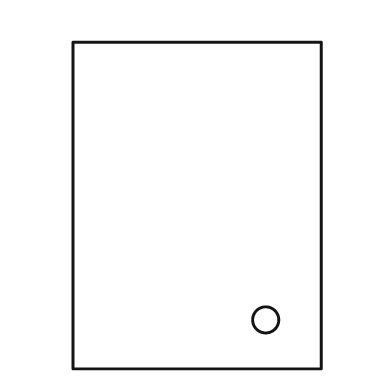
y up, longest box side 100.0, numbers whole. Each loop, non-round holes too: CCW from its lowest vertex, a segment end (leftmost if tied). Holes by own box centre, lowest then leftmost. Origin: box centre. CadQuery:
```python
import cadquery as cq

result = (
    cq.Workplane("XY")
    .moveTo(-38.0, -50.0)
    .lineTo(38.0, -50.0)
    .lineTo(38.0, 50.0)
    .lineTo(-38.0, 50.0)
    .close()
    .moveTo(21.0, -35.0)
    .circle(4.0)
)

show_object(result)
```